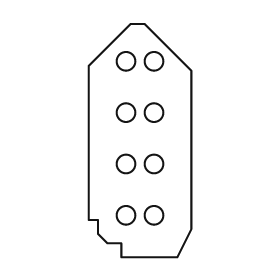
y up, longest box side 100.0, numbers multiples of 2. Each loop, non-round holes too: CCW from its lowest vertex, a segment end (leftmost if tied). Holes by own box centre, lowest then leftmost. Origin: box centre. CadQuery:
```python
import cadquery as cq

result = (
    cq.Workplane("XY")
    .moveTo(-8.0, -50.0)
    .lineTo(16.0, -50.0)
    .lineTo(22.0, -38.0)
    .lineTo(22.0, 30.0)
    .lineTo(2.0, 50.0)
    .lineTo(-4.0, 50.0)
    .lineTo(-22.0, 32.0)
    .lineTo(-22.0, -34.0)
    .lineTo(-18.0, -34.0)
    .lineTo(-18.0, -40.0)
    .lineTo(-14.0, -44.0)
    .lineTo(-8.0, -44.0)
    .close()
    .moveTo(-6.0, -32.0)
    .circle(4.0)
    .moveTo(6.0, -32.0)
    .circle(4.0)
    .moveTo(-6.0, -10.0)
    .circle(4.0)
    .moveTo(6.0, -10.0)
    .circle(4.0)
    .moveTo(-6.0, 12.0)
    .circle(4.0)
    .moveTo(6.0, 12.0)
    .circle(4.0)
    .moveTo(-6.0, 34.0)
    .circle(4.0)
    .moveTo(6.0, 34.0)
    .circle(4.0)
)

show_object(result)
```